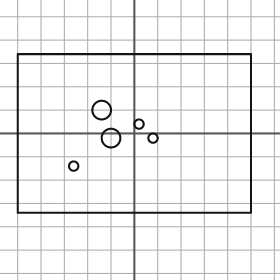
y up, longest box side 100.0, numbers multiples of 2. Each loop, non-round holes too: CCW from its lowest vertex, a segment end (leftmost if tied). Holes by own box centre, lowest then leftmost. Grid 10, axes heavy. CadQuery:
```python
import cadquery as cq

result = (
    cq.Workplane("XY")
    .moveTo(-50.0, -34.0)
    .lineTo(50.0, -34.0)
    .lineTo(50.0, 34.0)
    .lineTo(-50.0, 34.0)
    .close()
    .moveTo(-26.0, -14.0)
    .circle(2.0)
    .moveTo(-10.0, -2.0)
    .circle(4.0)
    .moveTo(8.0, -2.0)
    .circle(2.0)
    .moveTo(2.0, 4.0)
    .circle(2.0)
    .moveTo(-14.0, 10.0)
    .circle(4.0)
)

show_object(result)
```